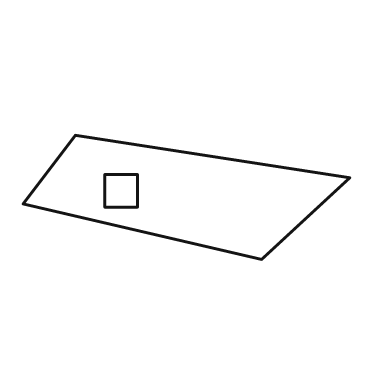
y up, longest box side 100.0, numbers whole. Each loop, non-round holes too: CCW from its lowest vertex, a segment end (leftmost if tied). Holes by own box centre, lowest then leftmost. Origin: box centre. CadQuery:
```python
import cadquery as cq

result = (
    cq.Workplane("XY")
    .moveTo(23.0, -19.0)
    .lineTo(50.0, 6.0)
    .lineTo(-34.0, 19.0)
    .lineTo(-50.0, -2.0)
    .close()
    .moveTo(-25.0, -3.0)
    .lineTo(-15.0, -3.0)
    .lineTo(-15.0, 7.0)
    .lineTo(-25.0, 7.0)
    .close()
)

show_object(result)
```